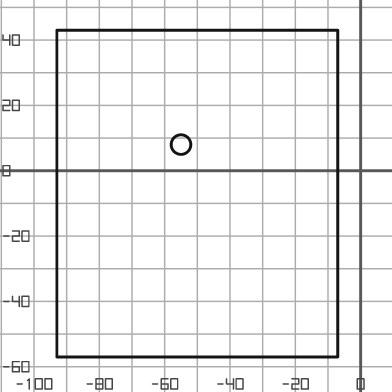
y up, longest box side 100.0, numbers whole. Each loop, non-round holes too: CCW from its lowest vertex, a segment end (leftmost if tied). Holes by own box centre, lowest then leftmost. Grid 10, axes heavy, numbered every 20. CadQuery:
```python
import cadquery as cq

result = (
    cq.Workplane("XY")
    .moveTo(-93.0, -57.0)
    .lineTo(-7.0, -57.0)
    .lineTo(-7.0, 43.0)
    .lineTo(-93.0, 43.0)
    .close()
    .moveTo(-55.0, 8.0)
    .circle(3.0)
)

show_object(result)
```